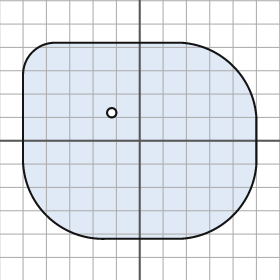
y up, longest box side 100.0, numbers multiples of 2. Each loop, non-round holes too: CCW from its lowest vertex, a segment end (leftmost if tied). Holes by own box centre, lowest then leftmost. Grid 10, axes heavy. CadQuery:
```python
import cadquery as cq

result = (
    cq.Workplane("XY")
    .moveTo(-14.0, -42.0)
    .lineTo(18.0, -42.0)
    .threePointArc((40.0, -32.0), (50.0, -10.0))
    .lineTo(50.0, 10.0)
    .threePointArc((40.0, 32.0), (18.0, 42.0))
    .lineTo(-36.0, 42.0)
    .threePointArc((-46.0, 38.0), (-50.0, 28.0))
    .lineTo(-50.0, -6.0)
    .threePointArc((-40.0, -32.0), (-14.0, -42.0))
    .close()
    .moveTo(-12.0, 12.0)
    .circle(2.0)
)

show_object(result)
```